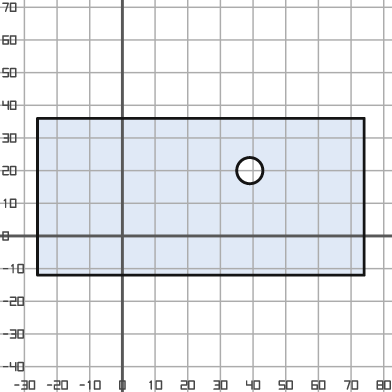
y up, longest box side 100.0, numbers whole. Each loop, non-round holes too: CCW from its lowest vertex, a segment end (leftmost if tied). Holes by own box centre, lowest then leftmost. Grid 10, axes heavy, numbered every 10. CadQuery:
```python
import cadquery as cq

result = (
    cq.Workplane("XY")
    .moveTo(-26.0, -12.0)
    .lineTo(74.0, -12.0)
    .lineTo(74.0, 36.0)
    .lineTo(-26.0, 36.0)
    .close()
    .moveTo(39.0, 20.0)
    .circle(4.0)
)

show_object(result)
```